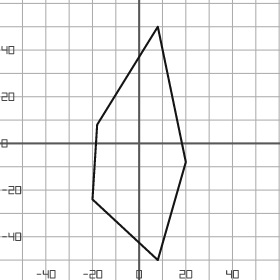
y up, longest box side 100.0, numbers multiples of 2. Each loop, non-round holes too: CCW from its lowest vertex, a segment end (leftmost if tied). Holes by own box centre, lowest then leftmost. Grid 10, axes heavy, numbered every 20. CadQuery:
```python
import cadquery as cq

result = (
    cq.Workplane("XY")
    .moveTo(8.0, -50.0)
    .lineTo(20.0, -8.0)
    .lineTo(8.0, 50.0)
    .lineTo(-18.0, 8.0)
    .lineTo(-20.0, -24.0)
    .close()
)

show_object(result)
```